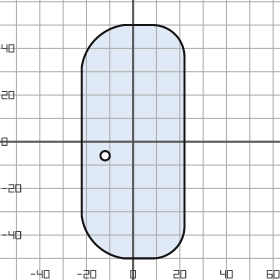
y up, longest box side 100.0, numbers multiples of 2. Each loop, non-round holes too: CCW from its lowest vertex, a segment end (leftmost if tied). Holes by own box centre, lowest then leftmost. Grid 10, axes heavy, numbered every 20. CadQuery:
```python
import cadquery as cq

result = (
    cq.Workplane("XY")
    .moveTo(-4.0, -50.0)
    .lineTo(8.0, -50.0)
    .threePointArc((18.0, -46.0), (22.0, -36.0))
    .lineTo(22.0, 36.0)
    .threePointArc((18.0, 46.0), (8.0, 50.0))
    .lineTo(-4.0, 50.0)
    .threePointArc((-16.0, 44.0), (-22.0, 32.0))
    .lineTo(-22.0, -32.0)
    .threePointArc((-16.0, -44.0), (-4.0, -50.0))
    .close()
    .moveTo(-12.0, -6.0)
    .circle(2.0)
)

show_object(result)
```